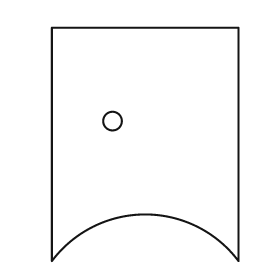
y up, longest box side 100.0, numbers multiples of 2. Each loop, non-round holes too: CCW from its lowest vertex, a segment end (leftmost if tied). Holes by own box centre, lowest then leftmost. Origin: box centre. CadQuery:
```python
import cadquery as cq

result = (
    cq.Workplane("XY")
    .moveTo(-40.0, -50.0)
    .threePointArc((0.0, -30.0), (40.0, -50.0))
    .lineTo(40.0, 50.0)
    .lineTo(-40.0, 50.0)
    .close()
    .moveTo(-14.0, 10.0)
    .circle(4.0)
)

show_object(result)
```